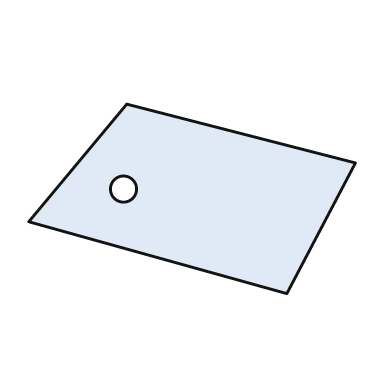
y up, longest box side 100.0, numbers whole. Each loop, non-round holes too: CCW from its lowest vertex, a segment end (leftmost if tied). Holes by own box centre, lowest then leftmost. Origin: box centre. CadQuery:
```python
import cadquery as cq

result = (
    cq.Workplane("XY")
    .moveTo(29.0, -29.0)
    .lineTo(50.0, 11.0)
    .lineTo(-20.0, 29.0)
    .lineTo(-50.0, -7.0)
    .close()
    .moveTo(-21.0, 3.0)
    .circle(4.0)
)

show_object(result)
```